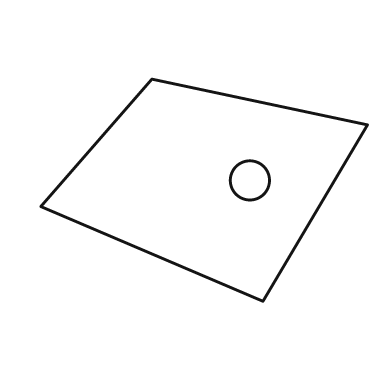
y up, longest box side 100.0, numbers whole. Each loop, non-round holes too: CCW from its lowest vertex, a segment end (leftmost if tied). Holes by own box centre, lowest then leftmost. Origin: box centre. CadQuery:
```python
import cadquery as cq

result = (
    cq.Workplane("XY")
    .moveTo(18.0, -34.0)
    .lineTo(50.0, 20.0)
    .lineTo(-16.0, 34.0)
    .lineTo(-50.0, -5.0)
    .close()
    .moveTo(14.0, 3.0)
    .circle(6.0)
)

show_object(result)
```